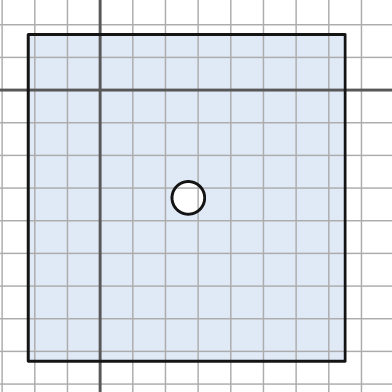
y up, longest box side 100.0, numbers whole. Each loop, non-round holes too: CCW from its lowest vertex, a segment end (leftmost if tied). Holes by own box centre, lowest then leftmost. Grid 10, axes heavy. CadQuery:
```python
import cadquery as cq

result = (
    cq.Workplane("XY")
    .moveTo(-22.0, -83.0)
    .lineTo(75.0, -83.0)
    .lineTo(75.0, 17.0)
    .lineTo(-22.0, 17.0)
    .close()
    .moveTo(27.0, -33.0)
    .circle(5.0)
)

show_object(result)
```